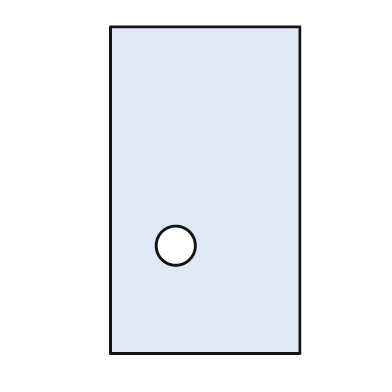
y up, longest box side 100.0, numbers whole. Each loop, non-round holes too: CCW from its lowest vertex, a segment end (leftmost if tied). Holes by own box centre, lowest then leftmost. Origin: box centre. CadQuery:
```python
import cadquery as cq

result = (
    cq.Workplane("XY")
    .moveTo(-29.0, -50.0)
    .lineTo(29.0, -50.0)
    .lineTo(29.0, 50.0)
    .lineTo(-29.0, 50.0)
    .close()
    .moveTo(-9.0, -17.0)
    .circle(6.0)
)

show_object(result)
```